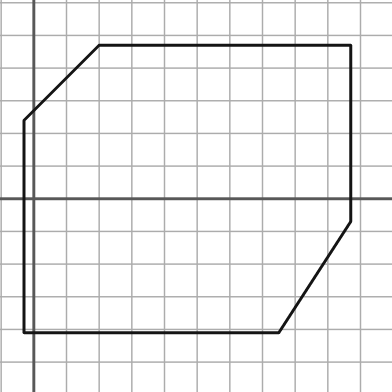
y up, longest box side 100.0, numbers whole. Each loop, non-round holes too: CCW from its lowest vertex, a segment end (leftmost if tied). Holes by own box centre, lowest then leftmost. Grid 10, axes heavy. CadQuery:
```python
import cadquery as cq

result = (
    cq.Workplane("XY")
    .moveTo(-3.0, -41.0)
    .lineTo(75.0, -41.0)
    .lineTo(97.0, -7.0)
    .lineTo(97.0, 47.0)
    .lineTo(20.0, 47.0)
    .lineTo(-3.0, 24.0)
    .close()
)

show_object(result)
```